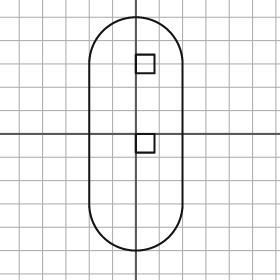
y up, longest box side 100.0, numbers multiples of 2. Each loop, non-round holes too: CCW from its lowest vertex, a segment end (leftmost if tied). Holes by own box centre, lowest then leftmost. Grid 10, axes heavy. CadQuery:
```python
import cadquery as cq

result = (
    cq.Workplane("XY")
    .moveTo(-20.0, -30.0)
    .threePointArc((0.0, -50.0), (20.0, -30.0))
    .lineTo(20.0, 30.0)
    .threePointArc((0.0, 50.0), (-20.0, 30.0))
    .close()
    .moveTo(0.0, -8.0)
    .lineTo(8.0, -8.0)
    .lineTo(8.0, 0.0)
    .lineTo(0.0, 0.0)
    .close()
    .moveTo(0.0, 26.0)
    .lineTo(8.0, 26.0)
    .lineTo(8.0, 34.0)
    .lineTo(0.0, 34.0)
    .close()
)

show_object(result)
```